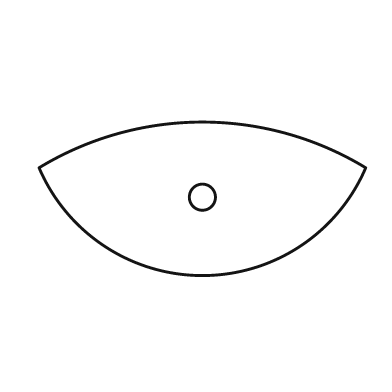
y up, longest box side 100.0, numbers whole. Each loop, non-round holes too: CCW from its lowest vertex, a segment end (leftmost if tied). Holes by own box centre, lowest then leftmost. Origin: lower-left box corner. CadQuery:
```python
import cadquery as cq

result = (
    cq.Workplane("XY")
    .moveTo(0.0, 33.0)
    .threePointArc((50.0, 0.0), (100.0, 33.0))
    .threePointArc((50.0, 47.0), (0.0, 33.0))
    .close()
    .moveTo(50.0, 24.0)
    .circle(4.0)
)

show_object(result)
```